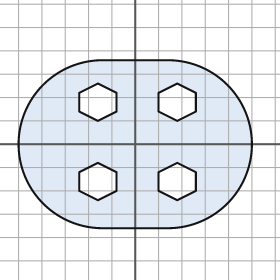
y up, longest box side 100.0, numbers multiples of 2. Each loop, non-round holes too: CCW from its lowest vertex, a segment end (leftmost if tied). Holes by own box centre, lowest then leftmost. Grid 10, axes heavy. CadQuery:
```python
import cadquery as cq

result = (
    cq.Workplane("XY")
    .moveTo(-14.0, -36.0)
    .lineTo(14.0, -36.0)
    .threePointArc((50.0, 0.0), (14.0, 36.0))
    .lineTo(-14.0, 36.0)
    .threePointArc((-50.0, 0.0), (-14.0, -36.0))
    .close()
    .moveTo(-16.0, -24.0)
    .lineTo(-8.0, -20.0)
    .lineTo(-8.0, -12.0)
    .lineTo(-16.0, -8.0)
    .lineTo(-24.0, -12.0)
    .lineTo(-24.0, -20.0)
    .close()
    .moveTo(18.0, -24.0)
    .lineTo(26.0, -20.0)
    .lineTo(26.0, -12.0)
    .lineTo(18.0, -8.0)
    .lineTo(10.0, -12.0)
    .lineTo(10.0, -20.0)
    .close()
    .moveTo(-16.0, 10.0)
    .lineTo(-8.0, 14.0)
    .lineTo(-8.0, 22.0)
    .lineTo(-16.0, 26.0)
    .lineTo(-24.0, 22.0)
    .lineTo(-24.0, 14.0)
    .close()
    .moveTo(18.0, 10.0)
    .lineTo(26.0, 14.0)
    .lineTo(26.0, 22.0)
    .lineTo(18.0, 26.0)
    .lineTo(10.0, 22.0)
    .lineTo(10.0, 14.0)
    .close()
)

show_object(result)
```